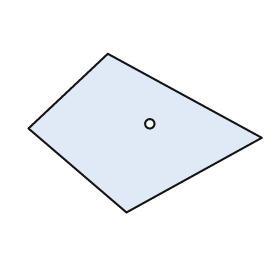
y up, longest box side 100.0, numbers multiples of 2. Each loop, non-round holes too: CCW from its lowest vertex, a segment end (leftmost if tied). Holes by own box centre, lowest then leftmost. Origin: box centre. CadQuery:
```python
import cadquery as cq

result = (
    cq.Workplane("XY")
    .moveTo(-8.0, -34.0)
    .lineTo(50.0, -2.0)
    .lineTo(-16.0, 34.0)
    .lineTo(-50.0, 2.0)
    .close()
    .moveTo(2.0, 4.0)
    .circle(2.0)
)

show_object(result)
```